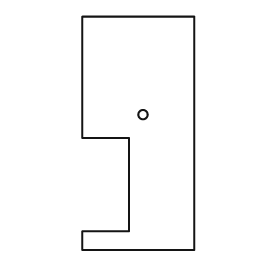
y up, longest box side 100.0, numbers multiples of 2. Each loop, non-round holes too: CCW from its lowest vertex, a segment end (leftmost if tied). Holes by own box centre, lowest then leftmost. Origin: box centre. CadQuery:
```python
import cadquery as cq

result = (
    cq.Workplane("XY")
    .moveTo(-24.0, -50.0)
    .lineTo(24.0, -50.0)
    .lineTo(24.0, 50.0)
    .lineTo(-24.0, 50.0)
    .lineTo(-24.0, -2.0)
    .lineTo(-4.0, -2.0)
    .lineTo(-4.0, -42.0)
    .lineTo(-24.0, -42.0)
    .close()
    .moveTo(2.0, 8.0)
    .circle(2.0)
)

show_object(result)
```